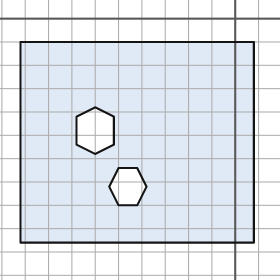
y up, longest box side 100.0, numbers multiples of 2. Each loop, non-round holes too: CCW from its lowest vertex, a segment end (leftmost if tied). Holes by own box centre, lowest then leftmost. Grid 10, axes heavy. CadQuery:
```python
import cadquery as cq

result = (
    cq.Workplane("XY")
    .moveTo(-92.0, -96.0)
    .lineTo(8.0, -96.0)
    .lineTo(8.0, -10.0)
    .lineTo(-92.0, -10.0)
    .close()
    .moveTo(-50.0, -80.0)
    .lineTo(-42.0, -80.0)
    .lineTo(-38.0, -72.0)
    .lineTo(-42.0, -64.0)
    .lineTo(-50.0, -64.0)
    .lineTo(-54.0, -72.0)
    .close()
    .moveTo(-60.0, -58.0)
    .lineTo(-52.0, -54.0)
    .lineTo(-52.0, -42.0)
    .lineTo(-60.0, -38.0)
    .lineTo(-68.0, -42.0)
    .lineTo(-68.0, -54.0)
    .close()
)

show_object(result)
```